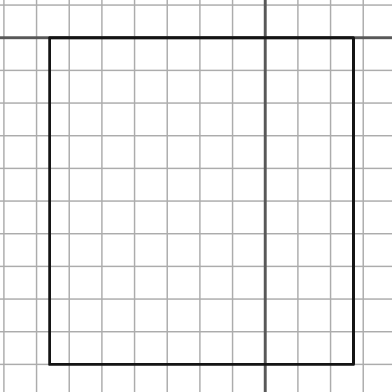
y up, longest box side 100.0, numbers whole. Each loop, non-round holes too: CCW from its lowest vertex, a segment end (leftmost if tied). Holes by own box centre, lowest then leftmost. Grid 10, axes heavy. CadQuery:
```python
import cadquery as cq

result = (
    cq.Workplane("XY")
    .moveTo(-66.0, -100.0)
    .lineTo(27.0, -100.0)
    .lineTo(27.0, 0.0)
    .lineTo(-66.0, 0.0)
    .close()
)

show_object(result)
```